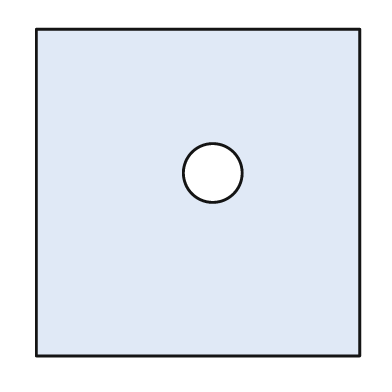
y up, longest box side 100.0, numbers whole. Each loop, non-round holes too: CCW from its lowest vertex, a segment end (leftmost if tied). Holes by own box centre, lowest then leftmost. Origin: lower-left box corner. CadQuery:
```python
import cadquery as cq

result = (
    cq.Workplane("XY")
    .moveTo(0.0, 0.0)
    .lineTo(99.0, 0.0)
    .lineTo(99.0, 100.0)
    .lineTo(0.0, 100.0)
    .close()
    .moveTo(54.0, 56.0)
    .circle(9.0)
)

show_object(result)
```